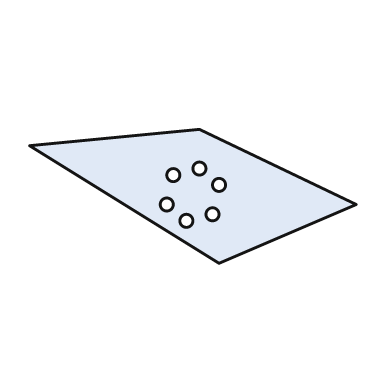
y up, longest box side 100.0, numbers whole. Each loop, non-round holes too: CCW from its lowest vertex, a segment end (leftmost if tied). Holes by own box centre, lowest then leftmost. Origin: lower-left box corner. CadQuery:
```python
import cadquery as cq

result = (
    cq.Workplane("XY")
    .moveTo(58.0, 0.0)
    .lineTo(100.0, 18.0)
    .lineTo(52.0, 41.0)
    .lineTo(0.0, 36.0)
    .close()
    .moveTo(48.0, 13.0)
    .circle(2.0)
    .moveTo(56.0, 15.0)
    .circle(2.0)
    .moveTo(42.0, 18.0)
    .circle(2.0)
    .moveTo(58.0, 24.0)
    .circle(2.0)
    .moveTo(44.0, 27.0)
    .circle(2.0)
    .moveTo(52.0, 29.0)
    .circle(2.0)
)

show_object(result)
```